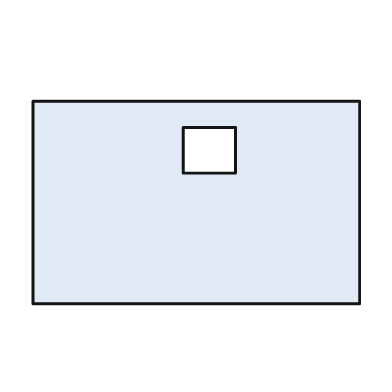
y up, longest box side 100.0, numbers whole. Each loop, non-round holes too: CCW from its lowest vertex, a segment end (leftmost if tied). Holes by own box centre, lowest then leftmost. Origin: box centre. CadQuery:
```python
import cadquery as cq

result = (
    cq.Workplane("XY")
    .moveTo(-50.0, -31.0)
    .lineTo(50.0, -31.0)
    .lineTo(50.0, 31.0)
    .lineTo(-50.0, 31.0)
    .close()
    .moveTo(-4.0, 9.0)
    .lineTo(12.0, 9.0)
    .lineTo(12.0, 23.0)
    .lineTo(-4.0, 23.0)
    .close()
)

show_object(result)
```